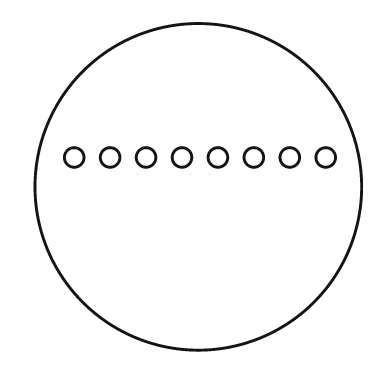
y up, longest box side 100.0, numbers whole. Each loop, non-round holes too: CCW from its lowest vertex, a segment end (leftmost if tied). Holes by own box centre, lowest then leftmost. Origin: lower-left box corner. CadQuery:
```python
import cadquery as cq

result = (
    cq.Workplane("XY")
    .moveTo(50.0, 50.0)
    .circle(50.0)
    .moveTo(12.0, 59.0)
    .circle(3.0)
    .moveTo(23.0, 59.0)
    .circle(3.0)
    .moveTo(34.0, 59.0)
    .circle(3.0)
    .moveTo(45.0, 59.0)
    .circle(3.0)
    .moveTo(56.0, 59.0)
    .circle(3.0)
    .moveTo(67.0, 59.0)
    .circle(3.0)
    .moveTo(78.0, 59.0)
    .circle(3.0)
    .moveTo(89.0, 59.0)
    .circle(3.0)
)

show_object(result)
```